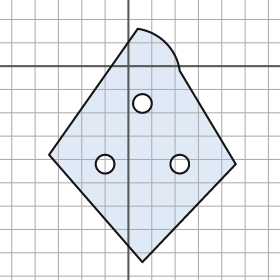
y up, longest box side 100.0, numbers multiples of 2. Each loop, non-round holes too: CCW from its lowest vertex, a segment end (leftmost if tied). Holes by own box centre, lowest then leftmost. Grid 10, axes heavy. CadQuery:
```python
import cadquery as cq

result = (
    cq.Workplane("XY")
    .moveTo(6.0, -84.0)
    .lineTo(46.0, -42.0)
    .lineTo(22.0, -2.0)
    .threePointArc((16.0, 10.0), (4.0, 16.0))
    .lineTo(-34.0, -38.0)
    .close()
    .moveTo(-10.0, -42.0)
    .circle(4.0)
    .moveTo(22.0, -42.0)
    .circle(4.0)
    .moveTo(6.0, -16.0)
    .circle(4.0)
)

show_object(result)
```